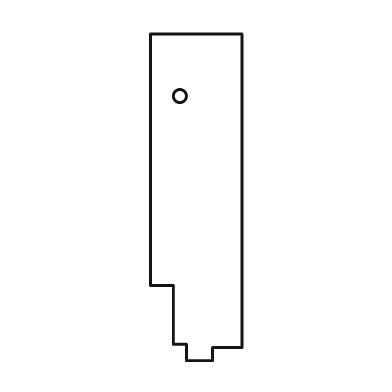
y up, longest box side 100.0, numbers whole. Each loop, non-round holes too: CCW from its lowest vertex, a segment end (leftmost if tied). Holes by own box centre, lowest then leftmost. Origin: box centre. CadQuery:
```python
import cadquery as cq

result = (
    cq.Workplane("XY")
    .moveTo(-3.0, -50.0)
    .lineTo(5.0, -50.0)
    .lineTo(5.0, -46.0)
    .lineTo(14.0, -46.0)
    .lineTo(14.0, 50.0)
    .lineTo(-14.0, 50.0)
    .lineTo(-14.0, -27.0)
    .lineTo(-7.0, -27.0)
    .lineTo(-7.0, -45.0)
    .lineTo(-3.0, -45.0)
    .close()
    .moveTo(-5.0, 31.0)
    .circle(2.0)
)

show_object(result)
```